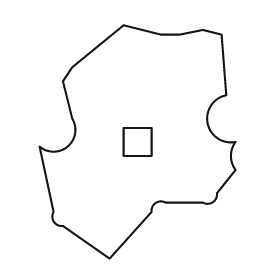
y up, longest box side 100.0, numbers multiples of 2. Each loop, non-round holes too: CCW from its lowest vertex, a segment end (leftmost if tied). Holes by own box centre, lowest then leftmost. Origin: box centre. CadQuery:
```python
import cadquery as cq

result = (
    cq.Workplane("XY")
    .moveTo(-12.0, -50.0)
    .lineTo(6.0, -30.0)
    .threePointArc((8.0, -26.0), (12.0, -26.0))
    .lineTo(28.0, -26.0)
    .threePointArc((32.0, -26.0), (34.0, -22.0))
    .lineTo(42.0, -12.0)
    .threePointArc((40.0, -6.0), (42.0, 0.0))
    .threePointArc((30.0, 8.0), (38.0, 20.0))
    .lineTo(36.0, 46.0)
    .lineTo(28.0, 48.0)
    .lineTo(18.0, 46.0)
    .lineTo(10.0, 46.0)
    .lineTo(-6.0, 50.0)
    .lineTo(-28.0, 32.0)
    .lineTo(-32.0, 26.0)
    .lineTo(-28.0, 10.0)
    .threePointArc((-30.0, -2.0), (-42.0, -2.0))
    .lineTo(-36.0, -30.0)
    .threePointArc((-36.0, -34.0), (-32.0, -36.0))
    .close()
    .moveTo(-6.0, -6.0)
    .lineTo(6.0, -6.0)
    .lineTo(6.0, 6.0)
    .lineTo(-6.0, 6.0)
    .close()
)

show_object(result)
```